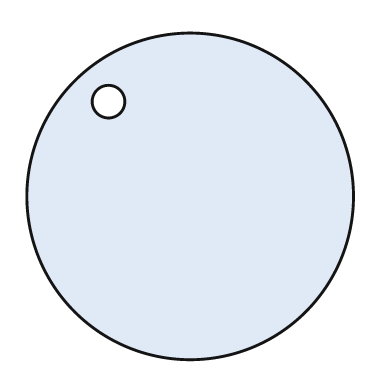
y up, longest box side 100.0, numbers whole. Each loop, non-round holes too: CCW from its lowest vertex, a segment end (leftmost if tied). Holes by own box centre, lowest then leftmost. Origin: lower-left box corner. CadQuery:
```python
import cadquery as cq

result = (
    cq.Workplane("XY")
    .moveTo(50.0, 50.0)
    .circle(50.0)
    .moveTo(25.0, 79.0)
    .circle(5.0)
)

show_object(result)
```